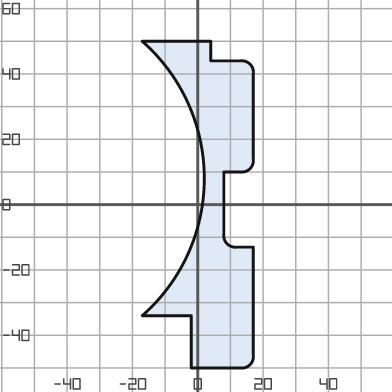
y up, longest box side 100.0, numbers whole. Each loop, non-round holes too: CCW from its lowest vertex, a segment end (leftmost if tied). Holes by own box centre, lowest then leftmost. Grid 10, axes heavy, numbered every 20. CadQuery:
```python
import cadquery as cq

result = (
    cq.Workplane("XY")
    .moveTo(-2.0, -50.0)
    .lineTo(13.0, -50.0)
    .threePointArc((16.0, -49.0), (17.0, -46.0))
    .lineTo(17.0, -13.0)
    .lineTo(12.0, -13.0)
    .threePointArc((9.0, -12.0), (8.0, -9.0))
    .lineTo(8.0, 10.0)
    .lineTo(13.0, 10.0)
    .threePointArc((16.0, 11.0), (17.0, 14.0))
    .lineTo(17.0, 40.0)
    .threePointArc((16.0, 43.0), (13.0, 44.0))
    .lineTo(4.0, 44.0)
    .lineTo(4.0, 50.0)
    .lineTo(-17.0, 50.0)
    .threePointArc((2.0, 8.0), (-17.0, -34.0))
    .lineTo(-2.0, -34.0)
    .close()
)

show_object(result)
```